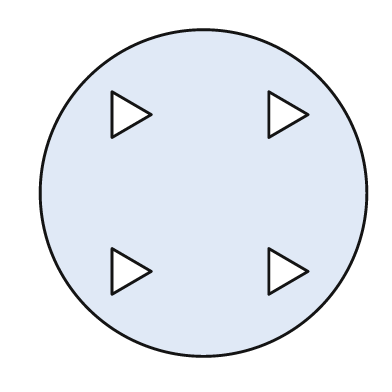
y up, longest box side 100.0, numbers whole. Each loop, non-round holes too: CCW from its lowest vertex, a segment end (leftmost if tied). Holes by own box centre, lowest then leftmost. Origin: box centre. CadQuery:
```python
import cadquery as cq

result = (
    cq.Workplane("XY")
    .moveTo(0.0, 0.0)
    .circle(50.0)
    .moveTo(-28.0, -31.0)
    .lineTo(-16.0, -24.0)
    .lineTo(-28.0, -17.0)
    .close()
    .moveTo(20.0, -31.0)
    .lineTo(32.0, -24.0)
    .lineTo(20.0, -17.0)
    .close()
    .moveTo(-28.0, 17.0)
    .lineTo(-16.0, 24.0)
    .lineTo(-28.0, 31.0)
    .close()
    .moveTo(20.0, 17.0)
    .lineTo(32.0, 24.0)
    .lineTo(20.0, 31.0)
    .close()
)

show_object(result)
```